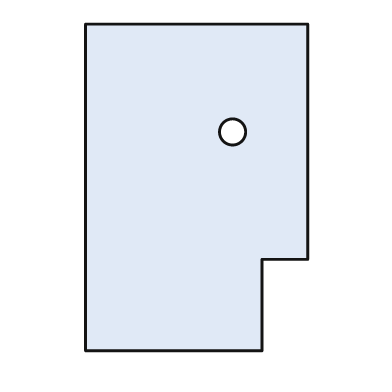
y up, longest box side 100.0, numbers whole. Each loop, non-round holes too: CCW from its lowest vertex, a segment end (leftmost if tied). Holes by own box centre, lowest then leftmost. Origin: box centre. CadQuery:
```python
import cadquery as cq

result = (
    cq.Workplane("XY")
    .moveTo(-34.0, -50.0)
    .lineTo(20.0, -50.0)
    .lineTo(20.0, -22.0)
    .lineTo(34.0, -22.0)
    .lineTo(34.0, 50.0)
    .lineTo(-34.0, 50.0)
    .close()
    .moveTo(11.0, 17.0)
    .circle(4.0)
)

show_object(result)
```